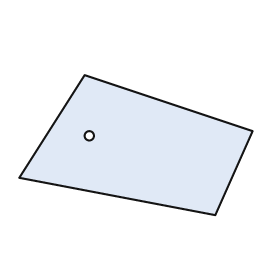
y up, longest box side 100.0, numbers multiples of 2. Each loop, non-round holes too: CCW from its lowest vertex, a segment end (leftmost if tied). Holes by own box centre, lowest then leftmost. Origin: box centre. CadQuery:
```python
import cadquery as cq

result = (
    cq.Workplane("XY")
    .moveTo(34.0, -30.0)
    .lineTo(50.0, 6.0)
    .lineTo(-22.0, 30.0)
    .lineTo(-50.0, -14.0)
    .close()
    .moveTo(-20.0, 4.0)
    .circle(2.0)
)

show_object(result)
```